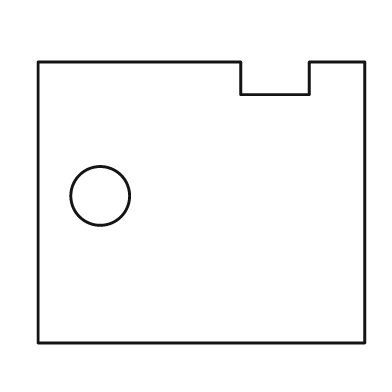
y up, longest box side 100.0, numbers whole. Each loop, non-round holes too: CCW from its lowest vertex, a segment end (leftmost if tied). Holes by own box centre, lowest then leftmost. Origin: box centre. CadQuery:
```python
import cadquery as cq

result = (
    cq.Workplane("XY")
    .moveTo(-50.0, -43.0)
    .lineTo(50.0, -43.0)
    .lineTo(50.0, 43.0)
    .lineTo(33.0, 43.0)
    .lineTo(33.0, 33.0)
    .lineTo(12.0, 33.0)
    .lineTo(12.0, 43.0)
    .lineTo(-50.0, 43.0)
    .close()
    .moveTo(-31.0, 2.0)
    .circle(9.0)
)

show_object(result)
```